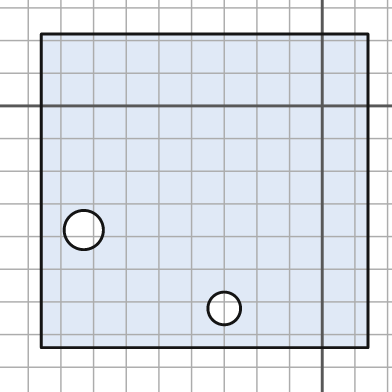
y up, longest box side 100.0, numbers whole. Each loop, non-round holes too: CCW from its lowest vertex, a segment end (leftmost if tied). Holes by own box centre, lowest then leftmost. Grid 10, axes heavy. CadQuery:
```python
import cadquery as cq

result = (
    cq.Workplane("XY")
    .moveTo(-86.0, -74.0)
    .lineTo(14.0, -74.0)
    .lineTo(14.0, 22.0)
    .lineTo(-86.0, 22.0)
    .close()
    .moveTo(-30.0, -62.0)
    .circle(5.0)
    .moveTo(-73.0, -38.0)
    .circle(6.0)
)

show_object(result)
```